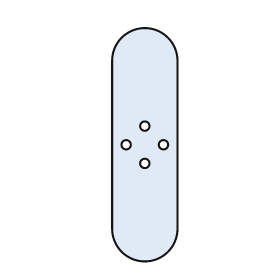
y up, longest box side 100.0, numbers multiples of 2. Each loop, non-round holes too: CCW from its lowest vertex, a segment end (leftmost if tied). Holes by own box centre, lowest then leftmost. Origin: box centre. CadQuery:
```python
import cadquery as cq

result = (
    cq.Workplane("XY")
    .moveTo(-14.0, -36.0)
    .threePointArc((0.0, -50.0), (14.0, -36.0))
    .lineTo(14.0, 36.0)
    .threePointArc((0.0, 50.0), (-14.0, 36.0))
    .close()
    .moveTo(0.0, -8.0)
    .circle(2.0)
    .moveTo(-8.0, 0.0)
    .circle(2.0)
    .moveTo(8.0, 0.0)
    .circle(2.0)
    .moveTo(0.0, 8.0)
    .circle(2.0)
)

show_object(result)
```